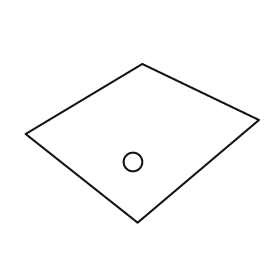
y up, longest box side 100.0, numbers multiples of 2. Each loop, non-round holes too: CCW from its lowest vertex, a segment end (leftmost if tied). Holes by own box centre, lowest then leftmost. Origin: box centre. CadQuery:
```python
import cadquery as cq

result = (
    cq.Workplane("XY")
    .moveTo(-2.0, -34.0)
    .lineTo(50.0, 10.0)
    .lineTo(0.0, 34.0)
    .lineTo(-50.0, 4.0)
    .close()
    .moveTo(-4.0, -8.0)
    .circle(4.0)
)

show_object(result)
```